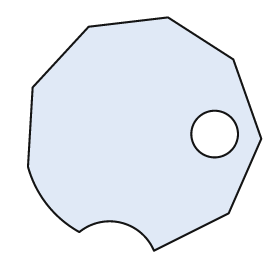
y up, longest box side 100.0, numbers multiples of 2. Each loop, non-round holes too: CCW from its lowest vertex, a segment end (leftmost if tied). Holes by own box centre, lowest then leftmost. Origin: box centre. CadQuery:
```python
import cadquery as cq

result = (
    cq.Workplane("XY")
    .moveTo(4.0, -50.0)
    .lineTo(36.0, -34.0)
    .lineTo(50.0, -2.0)
    .lineTo(38.0, 32.0)
    .lineTo(10.0, 50.0)
    .lineTo(-24.0, 46.0)
    .lineTo(-48.0, 20.0)
    .lineTo(-50.0, -14.0)
    .threePointArc((-42.0, -30.0), (-28.0, -42.0))
    .threePointArc((-10.0, -38.0), (4.0, -50.0))
    .close()
    .moveTo(30.0, 0.0)
    .circle(10.0)
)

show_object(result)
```